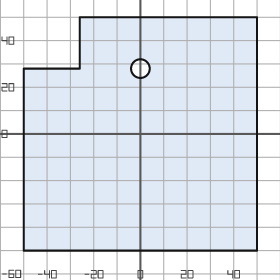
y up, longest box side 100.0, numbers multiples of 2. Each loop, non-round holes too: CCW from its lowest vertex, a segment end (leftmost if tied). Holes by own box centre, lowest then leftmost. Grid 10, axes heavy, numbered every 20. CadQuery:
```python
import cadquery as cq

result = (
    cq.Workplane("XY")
    .moveTo(-50.0, -50.0)
    .lineTo(50.0, -50.0)
    .lineTo(50.0, 50.0)
    .lineTo(-26.0, 50.0)
    .lineTo(-26.0, 28.0)
    .lineTo(-50.0, 28.0)
    .close()
    .moveTo(0.0, 28.0)
    .circle(4.0)
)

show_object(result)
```